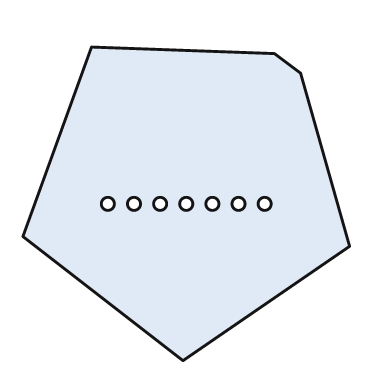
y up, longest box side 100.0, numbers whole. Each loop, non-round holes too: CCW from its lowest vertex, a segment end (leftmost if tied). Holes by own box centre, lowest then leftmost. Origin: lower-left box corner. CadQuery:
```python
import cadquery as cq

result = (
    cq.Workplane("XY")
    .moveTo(49.0, 0.0)
    .lineTo(100.0, 35.0)
    .lineTo(85.0, 88.0)
    .lineTo(77.0, 94.0)
    .lineTo(21.0, 96.0)
    .lineTo(0.0, 38.0)
    .close()
    .moveTo(26.0, 48.0)
    .circle(2.0)
    .moveTo(34.0, 48.0)
    .circle(2.0)
    .moveTo(42.0, 48.0)
    .circle(2.0)
    .moveTo(50.0, 48.0)
    .circle(2.0)
    .moveTo(58.0, 48.0)
    .circle(2.0)
    .moveTo(66.0, 48.0)
    .circle(2.0)
    .moveTo(74.0, 48.0)
    .circle(2.0)
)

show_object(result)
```